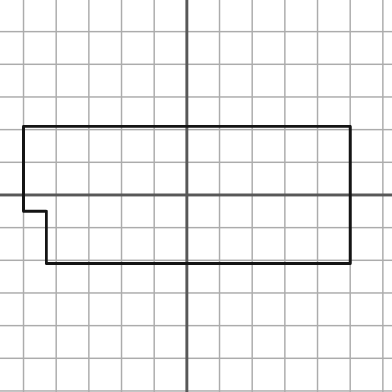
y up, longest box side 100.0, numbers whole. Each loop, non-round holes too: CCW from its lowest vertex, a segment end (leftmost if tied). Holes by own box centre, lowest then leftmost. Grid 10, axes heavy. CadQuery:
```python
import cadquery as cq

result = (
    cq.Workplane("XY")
    .moveTo(-43.0, -21.0)
    .lineTo(50.0, -21.0)
    .lineTo(50.0, 21.0)
    .lineTo(-50.0, 21.0)
    .lineTo(-50.0, -5.0)
    .lineTo(-43.0, -5.0)
    .close()
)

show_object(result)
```